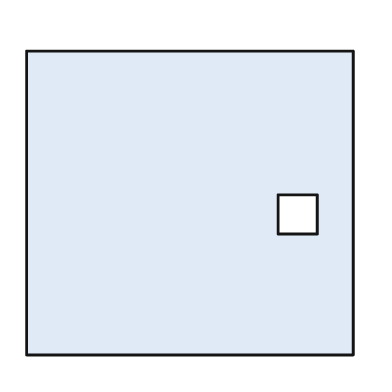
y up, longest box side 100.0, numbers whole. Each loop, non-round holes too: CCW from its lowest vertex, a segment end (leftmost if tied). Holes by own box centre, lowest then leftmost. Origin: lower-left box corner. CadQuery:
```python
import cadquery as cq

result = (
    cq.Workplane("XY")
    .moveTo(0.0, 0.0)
    .lineTo(100.0, 0.0)
    .lineTo(100.0, 93.0)
    .lineTo(0.0, 93.0)
    .close()
    .moveTo(77.0, 37.0)
    .lineTo(89.0, 37.0)
    .lineTo(89.0, 49.0)
    .lineTo(77.0, 49.0)
    .close()
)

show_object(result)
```